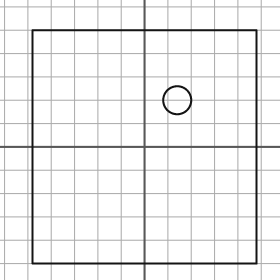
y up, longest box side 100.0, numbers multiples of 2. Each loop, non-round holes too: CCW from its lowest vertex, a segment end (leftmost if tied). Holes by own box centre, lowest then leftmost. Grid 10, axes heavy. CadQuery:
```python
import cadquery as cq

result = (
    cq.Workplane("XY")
    .moveTo(-48.0, -50.0)
    .lineTo(48.0, -50.0)
    .lineTo(48.0, 50.0)
    .lineTo(-48.0, 50.0)
    .close()
    .moveTo(14.0, 20.0)
    .circle(6.0)
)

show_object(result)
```